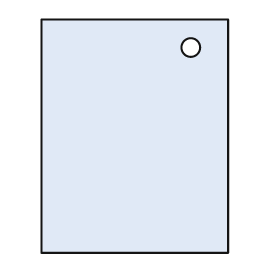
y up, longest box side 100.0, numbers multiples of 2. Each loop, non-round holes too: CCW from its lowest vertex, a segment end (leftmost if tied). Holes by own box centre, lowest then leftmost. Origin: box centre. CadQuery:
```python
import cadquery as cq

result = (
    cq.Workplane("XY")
    .moveTo(-40.0, -50.0)
    .lineTo(40.0, -50.0)
    .lineTo(40.0, 50.0)
    .lineTo(-40.0, 50.0)
    .close()
    .moveTo(24.0, 38.0)
    .circle(4.0)
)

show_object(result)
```